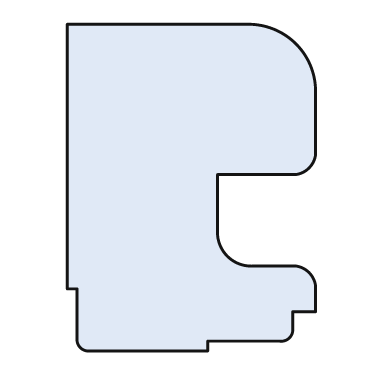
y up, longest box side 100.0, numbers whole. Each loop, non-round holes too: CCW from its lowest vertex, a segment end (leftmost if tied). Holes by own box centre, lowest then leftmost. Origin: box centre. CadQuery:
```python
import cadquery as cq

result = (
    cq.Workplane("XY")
    .moveTo(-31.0, -50.0)
    .lineTo(5.0, -50.0)
    .lineTo(5.0, -47.0)
    .lineTo(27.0, -47.0)
    .threePointArc((30.0, -46.0), (31.0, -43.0))
    .lineTo(31.0, -38.0)
    .lineTo(38.0, -38.0)
    .lineTo(38.0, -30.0)
    .threePointArc((36.0, -26.0), (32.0, -24.0))
    .lineTo(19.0, -24.0)
    .threePointArc((11.0, -21.0), (8.0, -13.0))
    .lineTo(8.0, 4.0)
    .lineTo(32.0, 4.0)
    .threePointArc((36.0, 6.0), (38.0, 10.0))
    .lineTo(38.0, 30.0)
    .threePointArc((32.0, 44.0), (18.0, 50.0))
    .lineTo(-38.0, 50.0)
    .lineTo(-38.0, -31.0)
    .lineTo(-35.0, -31.0)
    .lineTo(-35.0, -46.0)
    .threePointArc((-34.0, -49.0), (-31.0, -50.0))
    .close()
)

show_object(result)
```